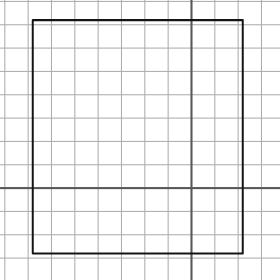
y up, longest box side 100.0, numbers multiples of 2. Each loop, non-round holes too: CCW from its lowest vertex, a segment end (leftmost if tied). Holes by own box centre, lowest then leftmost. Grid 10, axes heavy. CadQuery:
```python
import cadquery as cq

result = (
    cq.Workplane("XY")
    .moveTo(-68.0, -28.0)
    .lineTo(22.0, -28.0)
    .lineTo(22.0, 72.0)
    .lineTo(-68.0, 72.0)
    .close()
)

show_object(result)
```